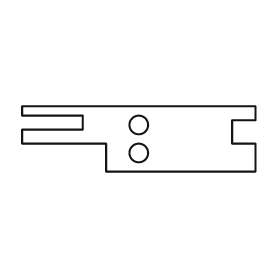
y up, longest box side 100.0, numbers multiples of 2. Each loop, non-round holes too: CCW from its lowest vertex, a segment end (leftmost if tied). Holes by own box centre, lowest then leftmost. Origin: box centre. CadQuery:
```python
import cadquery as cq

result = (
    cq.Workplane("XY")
    .moveTo(-14.0, -14.0)
    .lineTo(50.0, -14.0)
    .lineTo(50.0, -2.0)
    .lineTo(40.0, -2.0)
    .lineTo(40.0, 8.0)
    .lineTo(50.0, 8.0)
    .lineTo(50.0, 14.0)
    .lineTo(-50.0, 14.0)
    .lineTo(-50.0, 10.0)
    .lineTo(-24.0, 10.0)
    .lineTo(-24.0, 4.0)
    .lineTo(-50.0, 4.0)
    .lineTo(-50.0, -2.0)
    .lineTo(-14.0, -2.0)
    .close()
    .moveTo(0.0, -6.0)
    .circle(4.0)
    .moveTo(0.0, 6.0)
    .circle(4.0)
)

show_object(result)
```